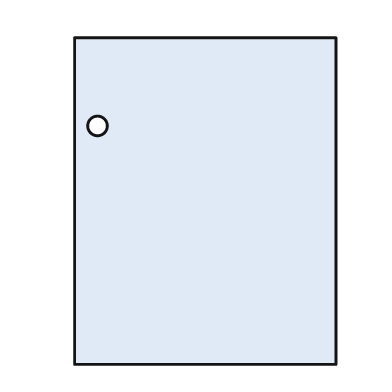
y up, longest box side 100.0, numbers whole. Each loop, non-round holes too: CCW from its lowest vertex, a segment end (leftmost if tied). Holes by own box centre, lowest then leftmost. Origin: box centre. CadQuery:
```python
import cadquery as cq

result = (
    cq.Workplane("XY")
    .moveTo(-40.0, -50.0)
    .lineTo(40.0, -50.0)
    .lineTo(40.0, 50.0)
    .lineTo(-40.0, 50.0)
    .close()
    .moveTo(-33.0, 23.0)
    .circle(3.0)
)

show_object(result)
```